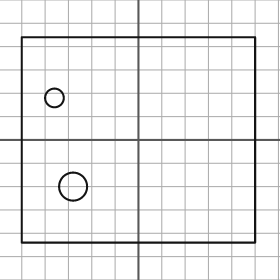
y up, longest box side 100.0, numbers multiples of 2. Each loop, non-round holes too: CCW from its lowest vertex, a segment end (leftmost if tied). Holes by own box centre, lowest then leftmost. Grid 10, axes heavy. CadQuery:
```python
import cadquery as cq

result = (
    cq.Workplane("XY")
    .moveTo(-50.0, -44.0)
    .lineTo(50.0, -44.0)
    .lineTo(50.0, 44.0)
    .lineTo(-50.0, 44.0)
    .close()
    .moveTo(-28.0, -20.0)
    .circle(6.0)
    .moveTo(-36.0, 18.0)
    .circle(4.0)
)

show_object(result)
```